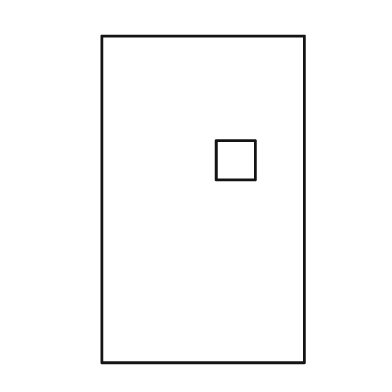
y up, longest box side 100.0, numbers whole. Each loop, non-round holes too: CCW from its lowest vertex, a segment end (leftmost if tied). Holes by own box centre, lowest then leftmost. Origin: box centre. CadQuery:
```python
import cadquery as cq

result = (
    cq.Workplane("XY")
    .moveTo(-31.0, -50.0)
    .lineTo(31.0, -50.0)
    .lineTo(31.0, 50.0)
    .lineTo(-31.0, 50.0)
    .close()
    .moveTo(4.0, 6.0)
    .lineTo(16.0, 6.0)
    .lineTo(16.0, 18.0)
    .lineTo(4.0, 18.0)
    .close()
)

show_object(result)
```